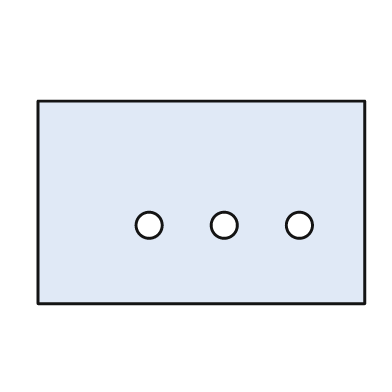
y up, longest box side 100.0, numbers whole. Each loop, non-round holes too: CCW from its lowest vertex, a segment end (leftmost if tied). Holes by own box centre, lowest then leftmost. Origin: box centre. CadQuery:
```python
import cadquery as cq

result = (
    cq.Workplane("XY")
    .moveTo(-50.0, -31.0)
    .lineTo(50.0, -31.0)
    .lineTo(50.0, 31.0)
    .lineTo(-50.0, 31.0)
    .close()
    .moveTo(-16.0, -7.0)
    .circle(4.0)
    .moveTo(7.0, -7.0)
    .circle(4.0)
    .moveTo(30.0, -7.0)
    .circle(4.0)
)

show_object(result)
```